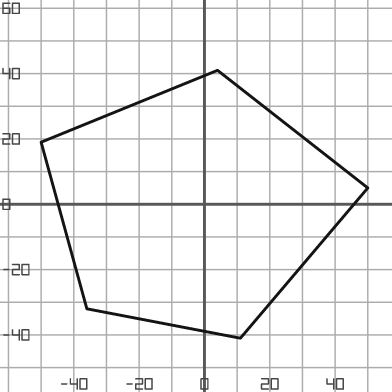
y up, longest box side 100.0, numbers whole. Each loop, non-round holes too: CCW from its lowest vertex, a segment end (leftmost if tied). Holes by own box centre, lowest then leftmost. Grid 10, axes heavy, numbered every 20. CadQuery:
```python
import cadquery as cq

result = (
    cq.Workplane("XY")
    .moveTo(11.0, -41.0)
    .lineTo(50.0, 5.0)
    .lineTo(4.0, 41.0)
    .lineTo(-50.0, 19.0)
    .lineTo(-36.0, -32.0)
    .close()
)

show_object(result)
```